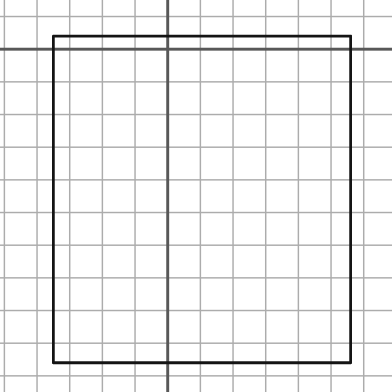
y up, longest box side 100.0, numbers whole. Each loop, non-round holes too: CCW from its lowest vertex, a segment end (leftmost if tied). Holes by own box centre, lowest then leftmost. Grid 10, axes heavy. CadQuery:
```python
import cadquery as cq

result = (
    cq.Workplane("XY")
    .moveTo(-35.0, -96.0)
    .lineTo(56.0, -96.0)
    .lineTo(56.0, 4.0)
    .lineTo(-35.0, 4.0)
    .close()
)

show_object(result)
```